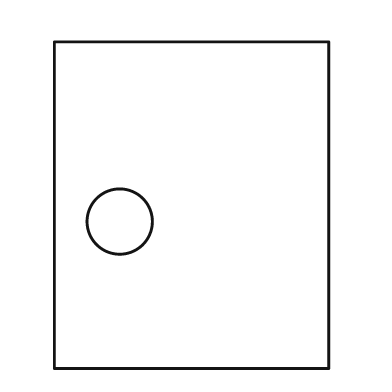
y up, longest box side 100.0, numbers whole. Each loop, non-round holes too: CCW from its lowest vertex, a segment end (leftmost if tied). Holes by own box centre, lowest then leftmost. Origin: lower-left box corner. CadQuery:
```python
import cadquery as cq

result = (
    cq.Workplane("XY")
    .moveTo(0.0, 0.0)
    .lineTo(84.0, 0.0)
    .lineTo(84.0, 100.0)
    .lineTo(0.0, 100.0)
    .close()
    .moveTo(20.0, 45.0)
    .circle(10.0)
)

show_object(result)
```